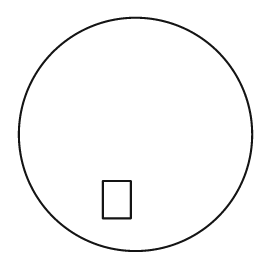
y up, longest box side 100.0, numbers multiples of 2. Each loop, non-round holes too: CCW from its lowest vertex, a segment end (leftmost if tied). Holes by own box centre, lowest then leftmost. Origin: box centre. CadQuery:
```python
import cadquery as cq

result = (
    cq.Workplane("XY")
    .moveTo(0.0, 0.0)
    .circle(50.0)
    .moveTo(-14.0, -36.0)
    .lineTo(-2.0, -36.0)
    .lineTo(-2.0, -20.0)
    .lineTo(-14.0, -20.0)
    .close()
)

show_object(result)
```